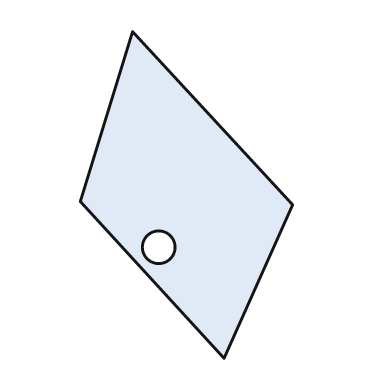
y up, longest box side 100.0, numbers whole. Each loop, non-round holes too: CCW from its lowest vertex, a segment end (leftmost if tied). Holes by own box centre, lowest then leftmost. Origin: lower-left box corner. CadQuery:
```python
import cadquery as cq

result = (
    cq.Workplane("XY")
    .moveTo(44.0, 0.0)
    .lineTo(65.0, 47.0)
    .lineTo(16.0, 100.0)
    .lineTo(0.0, 48.0)
    .close()
    .moveTo(24.0, 34.0)
    .circle(5.0)
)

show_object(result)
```